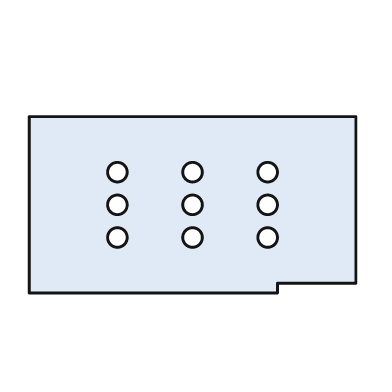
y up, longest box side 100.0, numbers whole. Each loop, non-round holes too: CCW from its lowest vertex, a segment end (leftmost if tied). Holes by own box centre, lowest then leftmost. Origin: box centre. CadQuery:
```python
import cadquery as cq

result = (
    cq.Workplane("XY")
    .moveTo(-50.0, -27.0)
    .lineTo(26.0, -27.0)
    .lineTo(26.0, -24.0)
    .lineTo(50.0, -24.0)
    .lineTo(50.0, 27.0)
    .lineTo(-50.0, 27.0)
    .close()
    .moveTo(-23.0, -10.0)
    .circle(3.0)
    .moveTo(0.0, -10.0)
    .circle(3.0)
    .moveTo(23.0, -10.0)
    .circle(3.0)
    .moveTo(-23.0, 0.0)
    .circle(3.0)
    .moveTo(0.0, 0.0)
    .circle(3.0)
    .moveTo(23.0, 0.0)
    .circle(3.0)
    .moveTo(-23.0, 10.0)
    .circle(3.0)
    .moveTo(0.0, 10.0)
    .circle(3.0)
    .moveTo(23.0, 10.0)
    .circle(3.0)
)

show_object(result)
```